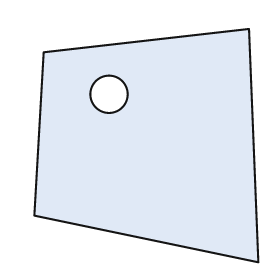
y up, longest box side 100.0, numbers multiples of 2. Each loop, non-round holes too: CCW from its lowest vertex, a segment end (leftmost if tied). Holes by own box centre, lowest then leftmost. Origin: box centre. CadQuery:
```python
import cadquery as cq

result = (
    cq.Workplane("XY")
    .moveTo(48.0, -50.0)
    .lineTo(44.0, 50.0)
    .lineTo(-44.0, 40.0)
    .lineTo(-48.0, -30.0)
    .close()
    .moveTo(-16.0, 22.0)
    .circle(8.0)
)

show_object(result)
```